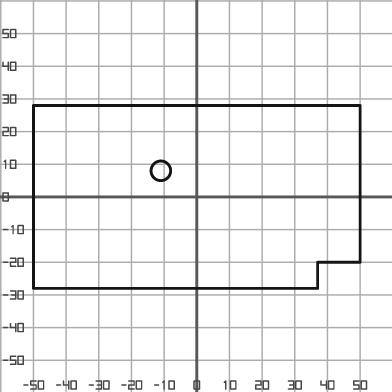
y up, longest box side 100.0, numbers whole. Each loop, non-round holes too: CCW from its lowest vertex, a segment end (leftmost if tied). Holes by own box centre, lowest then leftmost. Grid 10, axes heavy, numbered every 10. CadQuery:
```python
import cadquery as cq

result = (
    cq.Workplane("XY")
    .moveTo(-50.0, -28.0)
    .lineTo(37.0, -28.0)
    .lineTo(37.0, -20.0)
    .lineTo(50.0, -20.0)
    .lineTo(50.0, 28.0)
    .lineTo(-50.0, 28.0)
    .close()
    .moveTo(-11.0, 8.0)
    .circle(3.0)
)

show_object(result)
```